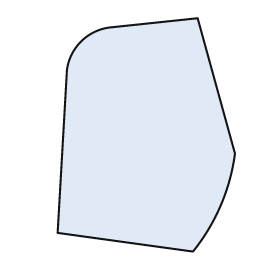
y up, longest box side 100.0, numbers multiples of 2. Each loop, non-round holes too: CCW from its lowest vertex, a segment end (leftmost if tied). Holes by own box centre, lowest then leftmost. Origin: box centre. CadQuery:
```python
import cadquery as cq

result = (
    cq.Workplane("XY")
    .moveTo(20.0, -50.0)
    .threePointArc((32.0, -30.0), (38.0, -8.0))
    .lineTo(22.0, 50.0)
    .lineTo(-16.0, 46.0)
    .threePointArc((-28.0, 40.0), (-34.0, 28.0))
    .lineTo(-38.0, -42.0)
    .close()
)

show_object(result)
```